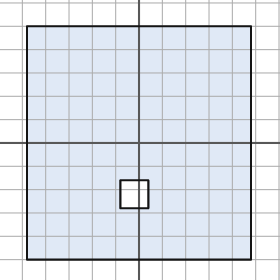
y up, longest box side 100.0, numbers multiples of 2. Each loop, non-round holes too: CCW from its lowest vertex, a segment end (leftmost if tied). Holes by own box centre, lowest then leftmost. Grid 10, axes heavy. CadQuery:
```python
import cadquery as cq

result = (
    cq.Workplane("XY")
    .moveTo(-48.0, -50.0)
    .lineTo(48.0, -50.0)
    .lineTo(48.0, 50.0)
    .lineTo(-48.0, 50.0)
    .close()
    .moveTo(-8.0, -28.0)
    .lineTo(4.0, -28.0)
    .lineTo(4.0, -16.0)
    .lineTo(-8.0, -16.0)
    .close()
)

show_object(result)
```